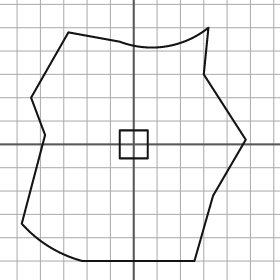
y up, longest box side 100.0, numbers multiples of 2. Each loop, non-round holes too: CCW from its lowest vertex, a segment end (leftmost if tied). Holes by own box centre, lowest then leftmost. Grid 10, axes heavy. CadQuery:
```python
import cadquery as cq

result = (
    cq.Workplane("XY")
    .moveTo(-22.0, -50.0)
    .lineTo(26.0, -50.0)
    .lineTo(34.0, -22.0)
    .lineTo(48.0, 2.0)
    .lineTo(30.0, 30.0)
    .lineTo(32.0, 50.0)
    .threePointArc((14.0, 42.0), (-6.0, 44.0))
    .lineTo(-28.0, 48.0)
    .lineTo(-44.0, 20.0)
    .lineTo(-38.0, 4.0)
    .lineTo(-48.0, -34.0)
    .threePointArc((-36.0, -44.0), (-22.0, -50.0))
    .close()
    .moveTo(-6.0, -6.0)
    .lineTo(6.0, -6.0)
    .lineTo(6.0, 6.0)
    .lineTo(-6.0, 6.0)
    .close()
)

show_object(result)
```